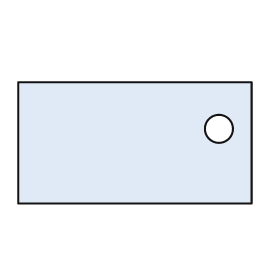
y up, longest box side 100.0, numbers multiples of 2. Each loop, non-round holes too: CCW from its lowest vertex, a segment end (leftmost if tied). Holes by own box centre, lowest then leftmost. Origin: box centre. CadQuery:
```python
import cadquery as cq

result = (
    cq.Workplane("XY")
    .moveTo(-50.0, -26.0)
    .lineTo(50.0, -26.0)
    .lineTo(50.0, 26.0)
    .lineTo(-50.0, 26.0)
    .close()
    .moveTo(36.0, 6.0)
    .circle(6.0)
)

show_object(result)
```